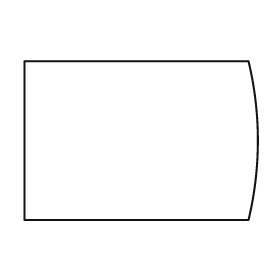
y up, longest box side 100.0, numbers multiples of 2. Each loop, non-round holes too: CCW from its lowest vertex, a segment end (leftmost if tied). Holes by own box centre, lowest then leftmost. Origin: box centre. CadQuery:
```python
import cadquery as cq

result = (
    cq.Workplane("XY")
    .moveTo(-50.0, -34.0)
    .lineTo(46.0, -34.0)
    .threePointArc((50.0, 0.0), (46.0, 34.0))
    .lineTo(-50.0, 34.0)
    .close()
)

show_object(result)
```